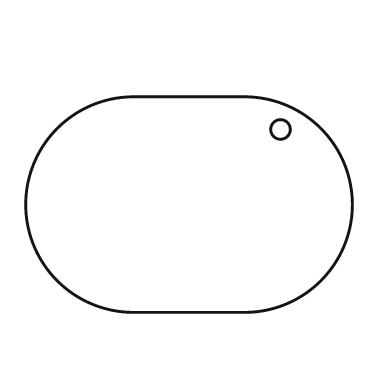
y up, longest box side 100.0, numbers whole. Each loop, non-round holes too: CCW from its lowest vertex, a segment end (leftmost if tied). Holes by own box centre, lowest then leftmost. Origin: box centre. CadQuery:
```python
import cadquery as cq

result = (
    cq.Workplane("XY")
    .moveTo(-17.0, -33.0)
    .lineTo(17.0, -33.0)
    .threePointArc((50.0, 0.0), (17.0, 33.0))
    .lineTo(-17.0, 33.0)
    .threePointArc((-50.0, 0.0), (-17.0, -33.0))
    .close()
    .moveTo(28.0, 23.0)
    .circle(3.0)
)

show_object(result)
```